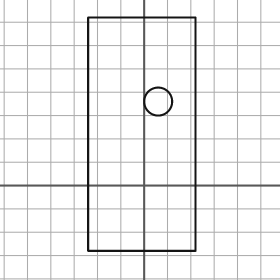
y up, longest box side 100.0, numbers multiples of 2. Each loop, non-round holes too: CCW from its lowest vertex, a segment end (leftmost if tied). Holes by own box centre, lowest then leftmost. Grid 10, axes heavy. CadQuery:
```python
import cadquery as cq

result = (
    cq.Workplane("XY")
    .moveTo(-24.0, -28.0)
    .lineTo(22.0, -28.0)
    .lineTo(22.0, 72.0)
    .lineTo(-24.0, 72.0)
    .close()
    .moveTo(6.0, 36.0)
    .circle(6.0)
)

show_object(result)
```